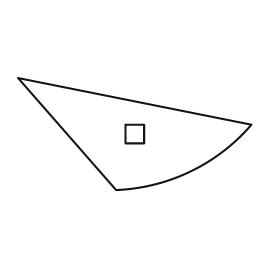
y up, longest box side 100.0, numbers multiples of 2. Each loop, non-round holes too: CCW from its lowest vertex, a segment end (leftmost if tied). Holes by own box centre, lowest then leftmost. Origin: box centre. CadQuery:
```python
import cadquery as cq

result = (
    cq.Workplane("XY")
    .moveTo(-8.0, -24.0)
    .threePointArc((24.0, -16.0), (50.0, 4.0))
    .lineTo(-50.0, 24.0)
    .close()
    .moveTo(-4.0, -4.0)
    .lineTo(4.0, -4.0)
    .lineTo(4.0, 4.0)
    .lineTo(-4.0, 4.0)
    .close()
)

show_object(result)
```